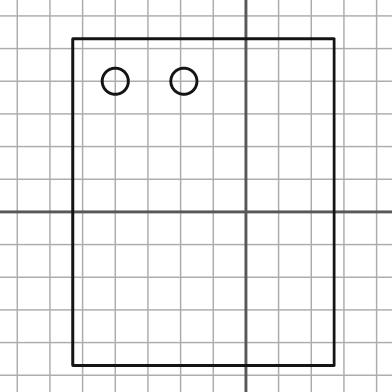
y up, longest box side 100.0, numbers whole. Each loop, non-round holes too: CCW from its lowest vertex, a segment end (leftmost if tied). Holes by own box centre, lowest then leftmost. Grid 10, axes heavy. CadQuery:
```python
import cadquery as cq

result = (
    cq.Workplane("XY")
    .moveTo(-53.0, -47.0)
    .lineTo(27.0, -47.0)
    .lineTo(27.0, 53.0)
    .lineTo(-53.0, 53.0)
    .close()
    .moveTo(-40.0, 40.0)
    .circle(4.0)
    .moveTo(-19.0, 40.0)
    .circle(4.0)
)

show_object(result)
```